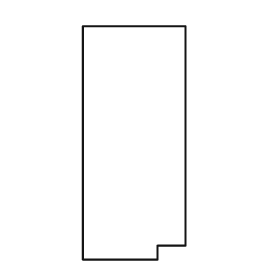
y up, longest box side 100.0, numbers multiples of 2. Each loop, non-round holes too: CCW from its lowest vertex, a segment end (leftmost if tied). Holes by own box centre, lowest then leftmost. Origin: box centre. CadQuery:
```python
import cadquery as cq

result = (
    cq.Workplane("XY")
    .moveTo(-22.0, -50.0)
    .lineTo(10.0, -50.0)
    .lineTo(10.0, -44.0)
    .lineTo(22.0, -44.0)
    .lineTo(22.0, 50.0)
    .lineTo(-22.0, 50.0)
    .close()
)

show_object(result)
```